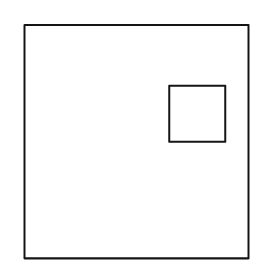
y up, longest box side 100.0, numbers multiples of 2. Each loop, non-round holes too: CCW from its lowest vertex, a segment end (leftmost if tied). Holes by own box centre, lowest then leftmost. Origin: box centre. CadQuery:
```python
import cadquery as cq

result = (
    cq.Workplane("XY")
    .moveTo(-48.0, -50.0)
    .lineTo(48.0, -50.0)
    .lineTo(48.0, 50.0)
    .lineTo(-48.0, 50.0)
    .close()
    .moveTo(14.0, 0.0)
    .lineTo(38.0, 0.0)
    .lineTo(38.0, 24.0)
    .lineTo(14.0, 24.0)
    .close()
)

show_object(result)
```